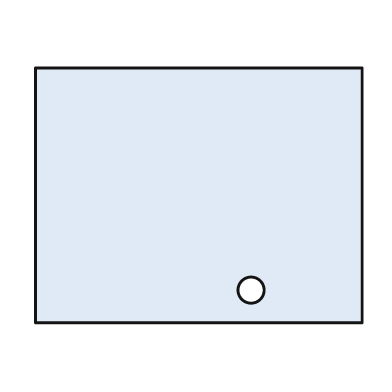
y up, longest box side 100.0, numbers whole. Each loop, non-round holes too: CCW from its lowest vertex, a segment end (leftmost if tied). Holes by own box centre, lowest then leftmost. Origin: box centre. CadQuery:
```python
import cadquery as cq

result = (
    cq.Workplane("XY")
    .moveTo(-50.0, -39.0)
    .lineTo(50.0, -39.0)
    .lineTo(50.0, 39.0)
    .lineTo(-50.0, 39.0)
    .close()
    .moveTo(16.0, -29.0)
    .circle(4.0)
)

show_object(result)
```